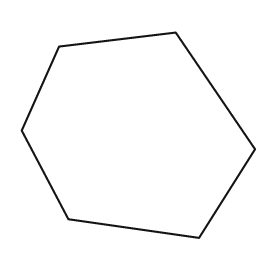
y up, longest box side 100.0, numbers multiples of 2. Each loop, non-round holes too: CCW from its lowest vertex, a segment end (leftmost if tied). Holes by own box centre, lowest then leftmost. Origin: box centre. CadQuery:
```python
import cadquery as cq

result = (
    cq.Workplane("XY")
    .moveTo(26.0, -44.0)
    .lineTo(50.0, -6.0)
    .lineTo(16.0, 44.0)
    .lineTo(-34.0, 38.0)
    .lineTo(-50.0, 2.0)
    .lineTo(-30.0, -36.0)
    .close()
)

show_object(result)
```